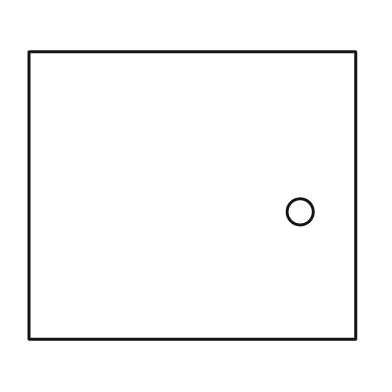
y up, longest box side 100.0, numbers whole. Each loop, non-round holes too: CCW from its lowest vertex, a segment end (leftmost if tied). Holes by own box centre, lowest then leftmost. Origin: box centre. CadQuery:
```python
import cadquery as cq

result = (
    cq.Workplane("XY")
    .moveTo(-50.0, -44.0)
    .lineTo(50.0, -44.0)
    .lineTo(50.0, 44.0)
    .lineTo(-50.0, 44.0)
    .close()
    .moveTo(33.0, -5.0)
    .circle(4.0)
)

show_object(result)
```